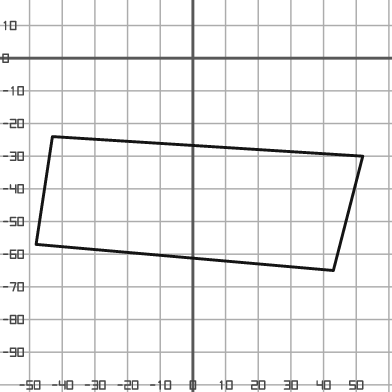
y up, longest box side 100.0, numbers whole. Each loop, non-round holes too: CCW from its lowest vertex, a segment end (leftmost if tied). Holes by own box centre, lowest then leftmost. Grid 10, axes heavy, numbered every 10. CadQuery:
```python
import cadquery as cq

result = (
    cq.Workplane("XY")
    .moveTo(43.0, -65.0)
    .lineTo(52.0, -30.0)
    .lineTo(-43.0, -24.0)
    .lineTo(-48.0, -57.0)
    .close()
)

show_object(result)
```